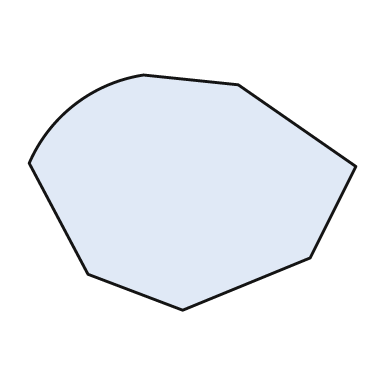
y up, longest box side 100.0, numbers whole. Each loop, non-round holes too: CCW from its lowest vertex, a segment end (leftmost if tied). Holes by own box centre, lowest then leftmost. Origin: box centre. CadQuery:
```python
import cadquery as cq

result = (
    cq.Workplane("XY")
    .moveTo(-3.0, -36.0)
    .lineTo(36.0, -20.0)
    .lineTo(50.0, 8.0)
    .lineTo(14.0, 33.0)
    .lineTo(-15.0, 36.0)
    .threePointArc((-36.0, 27.0), (-50.0, 9.0))
    .lineTo(-32.0, -25.0)
    .close()
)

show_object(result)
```